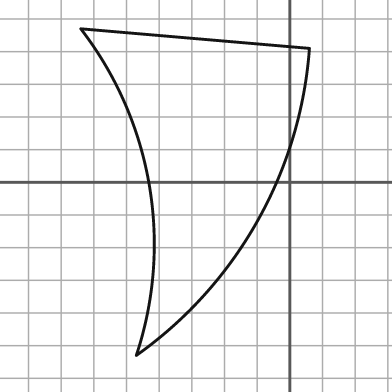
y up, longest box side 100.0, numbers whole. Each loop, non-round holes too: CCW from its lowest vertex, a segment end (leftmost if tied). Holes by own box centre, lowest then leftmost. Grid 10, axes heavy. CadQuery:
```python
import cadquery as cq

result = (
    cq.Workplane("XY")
    .moveTo(-47.0, -53.0)
    .threePointArc((-10.0, -12.0), (6.0, 41.0))
    .lineTo(-64.0, 47.0)
    .threePointArc((-43.0, -1.0), (-47.0, -53.0))
    .close()
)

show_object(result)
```